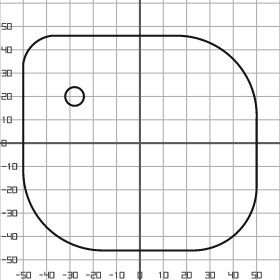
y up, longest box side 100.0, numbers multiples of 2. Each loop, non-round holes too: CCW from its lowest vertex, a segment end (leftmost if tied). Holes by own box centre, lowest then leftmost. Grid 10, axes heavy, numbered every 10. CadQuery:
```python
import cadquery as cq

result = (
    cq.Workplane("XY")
    .moveTo(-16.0, -46.0)
    .lineTo(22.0, -46.0)
    .threePointArc((42.0, -38.0), (50.0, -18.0))
    .lineTo(50.0, 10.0)
    .threePointArc((40.0, 36.0), (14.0, 46.0))
    .lineTo(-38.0, 46.0)
    .threePointArc((-46.0, 42.0), (-50.0, 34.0))
    .lineTo(-50.0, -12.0)
    .threePointArc((-40.0, -36.0), (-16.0, -46.0))
    .close()
    .moveTo(-28.0, 20.0)
    .circle(4.0)
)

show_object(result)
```